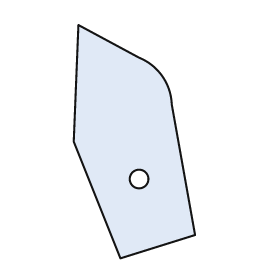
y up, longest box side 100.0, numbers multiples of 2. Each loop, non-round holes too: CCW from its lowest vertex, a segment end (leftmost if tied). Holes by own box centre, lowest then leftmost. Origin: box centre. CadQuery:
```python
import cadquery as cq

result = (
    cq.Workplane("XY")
    .moveTo(-6.0, -50.0)
    .lineTo(26.0, -40.0)
    .lineTo(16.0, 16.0)
    .threePointArc((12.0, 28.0), (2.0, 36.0))
    .lineTo(-24.0, 50.0)
    .lineTo(-26.0, 0.0)
    .close()
    .moveTo(2.0, -16.0)
    .circle(4.0)
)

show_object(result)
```